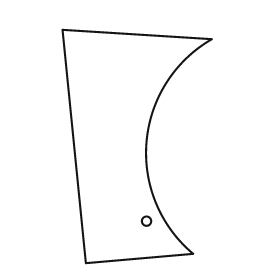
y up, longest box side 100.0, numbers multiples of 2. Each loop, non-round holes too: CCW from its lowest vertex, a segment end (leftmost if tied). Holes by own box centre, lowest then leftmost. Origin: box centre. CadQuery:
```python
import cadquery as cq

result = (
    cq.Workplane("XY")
    .moveTo(-22.0, -50.0)
    .lineTo(24.0, -46.0)
    .threePointArc((4.0, 2.0), (32.0, 46.0))
    .lineTo(-32.0, 50.0)
    .close()
    .moveTo(4.0, -32.0)
    .circle(2.0)
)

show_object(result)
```